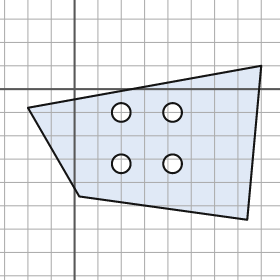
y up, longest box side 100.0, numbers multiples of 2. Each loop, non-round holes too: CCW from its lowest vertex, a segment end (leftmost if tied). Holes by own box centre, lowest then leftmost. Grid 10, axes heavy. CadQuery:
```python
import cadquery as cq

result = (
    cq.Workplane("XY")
    .moveTo(74.0, -56.0)
    .lineTo(80.0, 10.0)
    .lineTo(-20.0, -8.0)
    .lineTo(2.0, -46.0)
    .close()
    .moveTo(20.0, -32.0)
    .circle(4.0)
    .moveTo(42.0, -32.0)
    .circle(4.0)
    .moveTo(20.0, -10.0)
    .circle(4.0)
    .moveTo(42.0, -10.0)
    .circle(4.0)
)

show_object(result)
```